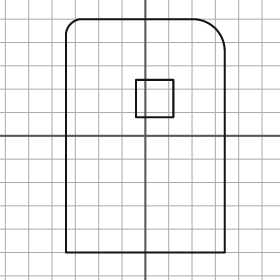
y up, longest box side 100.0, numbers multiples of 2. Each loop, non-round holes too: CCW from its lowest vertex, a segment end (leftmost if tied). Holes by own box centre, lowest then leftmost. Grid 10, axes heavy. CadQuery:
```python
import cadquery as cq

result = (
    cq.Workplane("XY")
    .moveTo(-34.0, -50.0)
    .lineTo(34.0, -50.0)
    .lineTo(34.0, 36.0)
    .threePointArc((30.0, 46.0), (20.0, 50.0))
    .lineTo(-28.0, 50.0)
    .threePointArc((-32.0, 48.0), (-34.0, 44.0))
    .close()
    .moveTo(-4.0, 8.0)
    .lineTo(12.0, 8.0)
    .lineTo(12.0, 24.0)
    .lineTo(-4.0, 24.0)
    .close()
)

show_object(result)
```